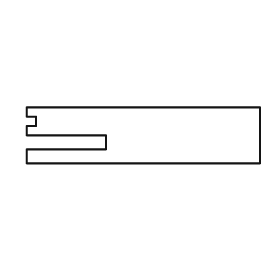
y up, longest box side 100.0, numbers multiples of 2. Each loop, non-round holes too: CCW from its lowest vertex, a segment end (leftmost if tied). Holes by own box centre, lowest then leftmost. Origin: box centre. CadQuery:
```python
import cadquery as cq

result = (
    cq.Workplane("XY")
    .moveTo(-50.0, -12.0)
    .lineTo(50.0, -12.0)
    .lineTo(50.0, 12.0)
    .lineTo(-50.0, 12.0)
    .lineTo(-50.0, 8.0)
    .lineTo(-46.0, 8.0)
    .lineTo(-46.0, 4.0)
    .lineTo(-50.0, 4.0)
    .lineTo(-50.0, 0.0)
    .lineTo(-16.0, 0.0)
    .lineTo(-16.0, -6.0)
    .lineTo(-50.0, -6.0)
    .close()
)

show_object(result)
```